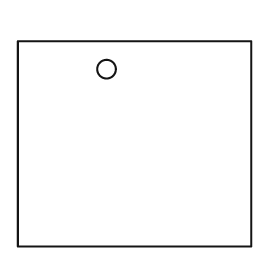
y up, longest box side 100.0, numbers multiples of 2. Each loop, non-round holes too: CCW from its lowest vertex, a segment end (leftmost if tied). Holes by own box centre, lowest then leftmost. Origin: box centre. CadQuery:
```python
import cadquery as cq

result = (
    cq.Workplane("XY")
    .moveTo(-50.0, -44.0)
    .lineTo(50.0, -44.0)
    .lineTo(50.0, 44.0)
    .lineTo(-50.0, 44.0)
    .close()
    .moveTo(-12.0, 32.0)
    .circle(4.0)
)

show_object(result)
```